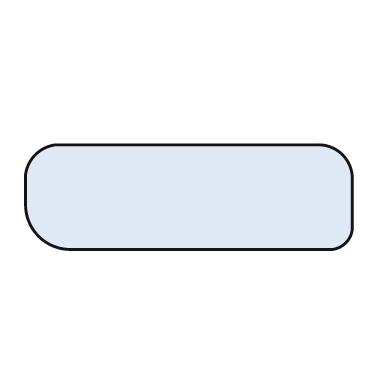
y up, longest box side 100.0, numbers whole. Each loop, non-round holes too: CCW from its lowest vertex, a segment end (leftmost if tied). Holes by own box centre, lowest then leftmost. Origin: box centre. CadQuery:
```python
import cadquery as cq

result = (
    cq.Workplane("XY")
    .moveTo(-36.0, -16.0)
    .lineTo(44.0, -16.0)
    .threePointArc((48.0, -14.0), (50.0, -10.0))
    .lineTo(50.0, 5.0)
    .threePointArc((47.0, 13.0), (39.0, 16.0))
    .lineTo(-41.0, 16.0)
    .threePointArc((-47.0, 13.0), (-50.0, 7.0))
    .lineTo(-50.0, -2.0)
    .threePointArc((-46.0, -12.0), (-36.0, -16.0))
    .close()
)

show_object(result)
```